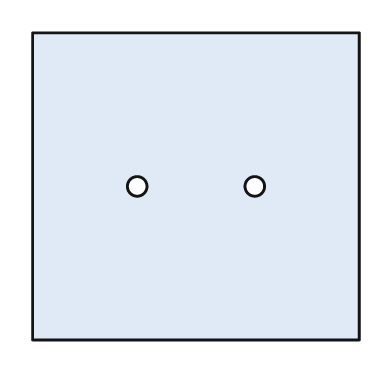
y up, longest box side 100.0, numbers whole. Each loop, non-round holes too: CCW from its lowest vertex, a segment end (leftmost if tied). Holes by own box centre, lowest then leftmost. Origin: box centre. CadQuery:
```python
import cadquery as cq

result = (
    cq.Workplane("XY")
    .moveTo(-50.0, -47.0)
    .lineTo(50.0, -47.0)
    .lineTo(50.0, 47.0)
    .lineTo(-50.0, 47.0)
    .close()
    .moveTo(-18.0, 0.0)
    .circle(3.0)
    .moveTo(18.0, 0.0)
    .circle(3.0)
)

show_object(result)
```